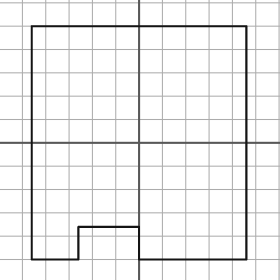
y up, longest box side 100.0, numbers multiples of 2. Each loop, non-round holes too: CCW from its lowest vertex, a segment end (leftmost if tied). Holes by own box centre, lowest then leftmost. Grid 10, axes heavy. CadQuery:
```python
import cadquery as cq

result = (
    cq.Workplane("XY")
    .moveTo(-46.0, -50.0)
    .lineTo(-26.0, -50.0)
    .lineTo(-26.0, -36.0)
    .lineTo(0.0, -36.0)
    .lineTo(0.0, -50.0)
    .lineTo(46.0, -50.0)
    .lineTo(46.0, 50.0)
    .lineTo(-46.0, 50.0)
    .close()
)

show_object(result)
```